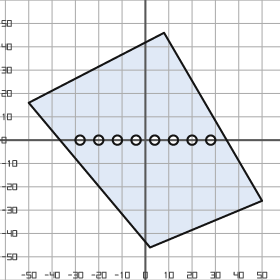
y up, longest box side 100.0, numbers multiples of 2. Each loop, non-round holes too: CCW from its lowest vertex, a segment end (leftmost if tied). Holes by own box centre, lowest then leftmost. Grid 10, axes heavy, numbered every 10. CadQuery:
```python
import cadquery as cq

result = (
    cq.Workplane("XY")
    .moveTo(2.0, -46.0)
    .lineTo(50.0, -26.0)
    .lineTo(8.0, 46.0)
    .lineTo(-50.0, 16.0)
    .close()
    .moveTo(-28.0, 0.0)
    .circle(2.0)
    .moveTo(-20.0, 0.0)
    .circle(2.0)
    .moveTo(-12.0, 0.0)
    .circle(2.0)
    .moveTo(-4.0, 0.0)
    .circle(2.0)
    .moveTo(4.0, 0.0)
    .circle(2.0)
    .moveTo(12.0, 0.0)
    .circle(2.0)
    .moveTo(20.0, 0.0)
    .circle(2.0)
    .moveTo(28.0, 0.0)
    .circle(2.0)
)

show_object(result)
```